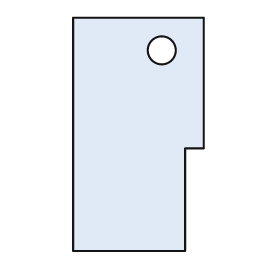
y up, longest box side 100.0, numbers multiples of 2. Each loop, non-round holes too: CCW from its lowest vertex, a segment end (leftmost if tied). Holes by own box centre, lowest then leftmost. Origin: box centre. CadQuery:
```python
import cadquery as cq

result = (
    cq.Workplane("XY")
    .moveTo(-28.0, -50.0)
    .lineTo(20.0, -50.0)
    .lineTo(20.0, -6.0)
    .lineTo(28.0, -6.0)
    .lineTo(28.0, 50.0)
    .lineTo(-28.0, 50.0)
    .close()
    .moveTo(10.0, 36.0)
    .circle(6.0)
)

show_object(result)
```